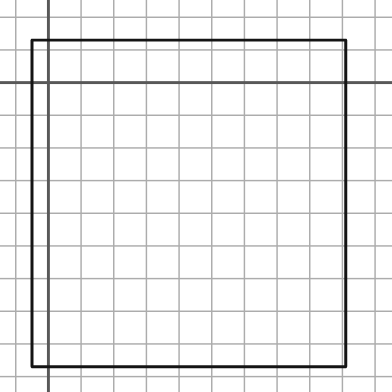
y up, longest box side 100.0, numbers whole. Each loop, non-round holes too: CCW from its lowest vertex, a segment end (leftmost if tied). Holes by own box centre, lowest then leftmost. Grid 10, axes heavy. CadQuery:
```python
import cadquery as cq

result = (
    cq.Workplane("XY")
    .moveTo(-5.0, -87.0)
    .lineTo(91.0, -87.0)
    .lineTo(91.0, 13.0)
    .lineTo(-5.0, 13.0)
    .close()
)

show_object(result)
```